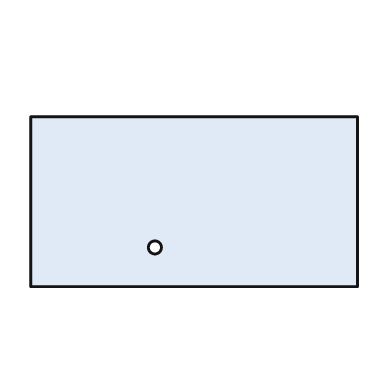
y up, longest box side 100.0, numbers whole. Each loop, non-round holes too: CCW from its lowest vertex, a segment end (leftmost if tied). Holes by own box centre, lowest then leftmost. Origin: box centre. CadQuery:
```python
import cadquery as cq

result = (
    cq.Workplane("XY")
    .moveTo(-50.0, -26.0)
    .lineTo(50.0, -26.0)
    .lineTo(50.0, 26.0)
    .lineTo(-50.0, 26.0)
    .close()
    .moveTo(-12.0, -14.0)
    .circle(2.0)
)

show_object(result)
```